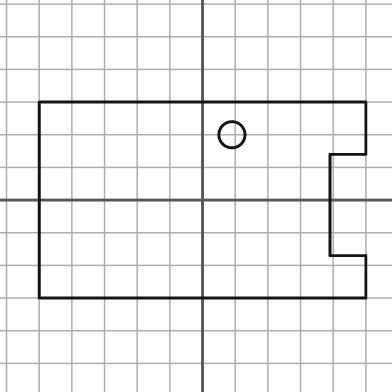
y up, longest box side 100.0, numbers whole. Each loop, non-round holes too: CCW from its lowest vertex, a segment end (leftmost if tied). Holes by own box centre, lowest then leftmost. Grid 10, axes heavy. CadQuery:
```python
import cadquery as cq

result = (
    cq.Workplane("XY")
    .moveTo(-50.0, -30.0)
    .lineTo(50.0, -30.0)
    .lineTo(50.0, -17.0)
    .lineTo(39.0, -17.0)
    .lineTo(39.0, 14.0)
    .lineTo(50.0, 14.0)
    .lineTo(50.0, 30.0)
    .lineTo(-50.0, 30.0)
    .close()
    .moveTo(9.0, 20.0)
    .circle(4.0)
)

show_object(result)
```